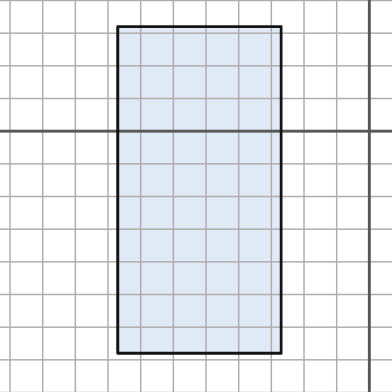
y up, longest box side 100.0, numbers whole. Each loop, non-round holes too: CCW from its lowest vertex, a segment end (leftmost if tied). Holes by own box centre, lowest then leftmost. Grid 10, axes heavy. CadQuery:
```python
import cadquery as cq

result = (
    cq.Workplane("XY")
    .moveTo(-77.0, -68.0)
    .lineTo(-27.0, -68.0)
    .lineTo(-27.0, 32.0)
    .lineTo(-77.0, 32.0)
    .close()
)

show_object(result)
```